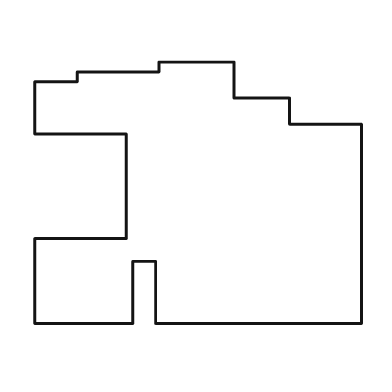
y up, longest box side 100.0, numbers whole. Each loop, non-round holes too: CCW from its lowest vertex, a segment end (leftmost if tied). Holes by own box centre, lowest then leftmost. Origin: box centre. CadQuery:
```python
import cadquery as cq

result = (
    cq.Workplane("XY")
    .moveTo(-50.0, -40.0)
    .lineTo(-20.0, -40.0)
    .lineTo(-20.0, -21.0)
    .lineTo(-13.0, -21.0)
    .lineTo(-13.0, -40.0)
    .lineTo(50.0, -40.0)
    .lineTo(50.0, 21.0)
    .lineTo(28.0, 21.0)
    .lineTo(28.0, 29.0)
    .lineTo(11.0, 29.0)
    .lineTo(11.0, 40.0)
    .lineTo(-12.0, 40.0)
    .lineTo(-12.0, 37.0)
    .lineTo(-37.0, 37.0)
    .lineTo(-37.0, 34.0)
    .lineTo(-50.0, 34.0)
    .lineTo(-50.0, 18.0)
    .lineTo(-22.0, 18.0)
    .lineTo(-22.0, -14.0)
    .lineTo(-50.0, -14.0)
    .close()
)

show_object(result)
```